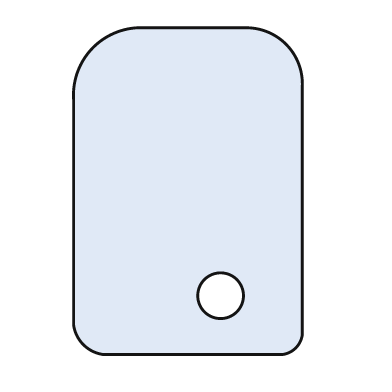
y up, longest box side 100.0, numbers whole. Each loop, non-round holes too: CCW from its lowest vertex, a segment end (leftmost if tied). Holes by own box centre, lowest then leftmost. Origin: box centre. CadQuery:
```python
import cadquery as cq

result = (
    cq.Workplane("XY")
    .moveTo(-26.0, -50.0)
    .lineTo(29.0, -50.0)
    .threePointArc((33.0, -48.0), (35.0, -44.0))
    .lineTo(35.0, 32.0)
    .threePointArc((30.0, 45.0), (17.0, 50.0))
    .lineTo(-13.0, 50.0)
    .threePointArc((-29.0, 44.0), (-35.0, 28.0))
    .lineTo(-35.0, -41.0)
    .threePointArc((-32.0, -47.0), (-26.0, -50.0))
    .close()
    .moveTo(10.0, -32.0)
    .circle(7.0)
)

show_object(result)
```